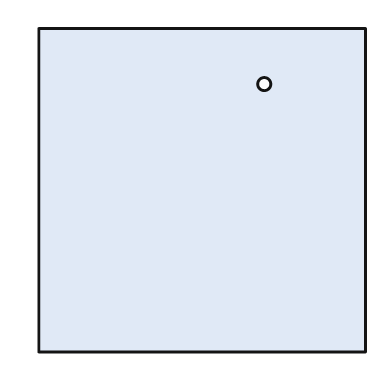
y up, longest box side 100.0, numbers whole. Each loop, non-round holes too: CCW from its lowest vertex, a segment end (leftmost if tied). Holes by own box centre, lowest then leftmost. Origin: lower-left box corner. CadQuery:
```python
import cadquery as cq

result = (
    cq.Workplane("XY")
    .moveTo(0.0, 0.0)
    .lineTo(100.0, 0.0)
    .lineTo(100.0, 99.0)
    .lineTo(0.0, 99.0)
    .close()
    .moveTo(69.0, 82.0)
    .circle(2.0)
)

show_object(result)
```